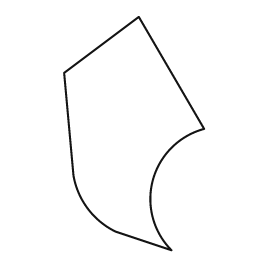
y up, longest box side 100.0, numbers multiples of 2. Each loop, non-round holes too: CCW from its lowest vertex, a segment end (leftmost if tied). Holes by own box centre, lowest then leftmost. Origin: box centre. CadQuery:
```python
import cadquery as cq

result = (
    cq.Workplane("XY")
    .moveTo(16.0, -50.0)
    .threePointArc((8.0, -20.0), (30.0, 2.0))
    .lineTo(2.0, 50.0)
    .lineTo(-30.0, 26.0)
    .lineTo(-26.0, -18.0)
    .threePointArc((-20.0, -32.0), (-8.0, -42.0))
    .close()
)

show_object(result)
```